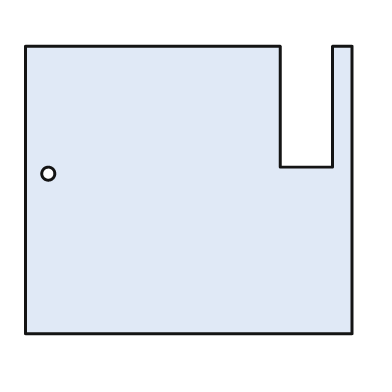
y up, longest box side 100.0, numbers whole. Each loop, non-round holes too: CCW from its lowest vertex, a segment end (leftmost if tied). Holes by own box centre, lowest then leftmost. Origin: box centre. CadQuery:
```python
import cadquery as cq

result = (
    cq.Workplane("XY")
    .moveTo(-50.0, -44.0)
    .lineTo(50.0, -44.0)
    .lineTo(50.0, 44.0)
    .lineTo(44.0, 44.0)
    .lineTo(44.0, 7.0)
    .lineTo(28.0, 7.0)
    .lineTo(28.0, 44.0)
    .lineTo(-50.0, 44.0)
    .close()
    .moveTo(-43.0, 5.0)
    .circle(2.0)
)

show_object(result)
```